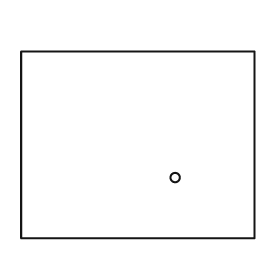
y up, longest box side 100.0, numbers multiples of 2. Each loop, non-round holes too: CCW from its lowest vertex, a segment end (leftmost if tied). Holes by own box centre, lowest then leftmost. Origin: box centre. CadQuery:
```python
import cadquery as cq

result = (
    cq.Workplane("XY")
    .moveTo(-50.0, -40.0)
    .lineTo(50.0, -40.0)
    .lineTo(50.0, 40.0)
    .lineTo(-50.0, 40.0)
    .close()
    .moveTo(16.0, -14.0)
    .circle(2.0)
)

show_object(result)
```